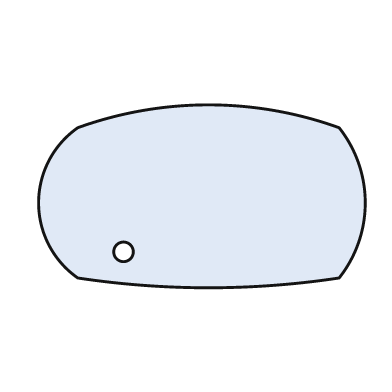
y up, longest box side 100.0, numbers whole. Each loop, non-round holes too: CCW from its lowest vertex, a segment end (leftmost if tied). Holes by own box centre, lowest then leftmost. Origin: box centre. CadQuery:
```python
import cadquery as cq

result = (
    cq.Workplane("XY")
    .moveTo(-38.0, -25.0)
    .threePointArc((2.0, -28.0), (42.0, -25.0))
    .threePointArc((50.0, -2.0), (42.0, 21.0))
    .threePointArc((2.0, 28.0), (-38.0, 21.0))
    .threePointArc((-50.0, -2.0), (-38.0, -25.0))
    .close()
    .moveTo(-24.0, -17.0)
    .circle(3.0)
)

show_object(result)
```